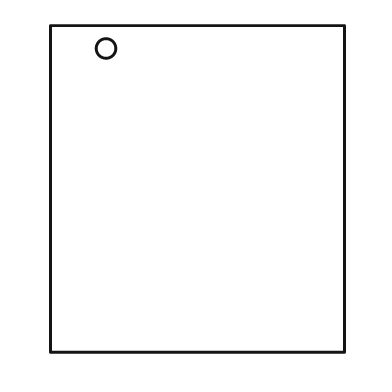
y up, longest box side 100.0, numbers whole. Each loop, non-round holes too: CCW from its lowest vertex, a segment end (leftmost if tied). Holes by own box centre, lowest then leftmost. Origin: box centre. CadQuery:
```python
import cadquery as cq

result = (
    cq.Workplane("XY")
    .moveTo(-45.0, -50.0)
    .lineTo(45.0, -50.0)
    .lineTo(45.0, 50.0)
    .lineTo(-45.0, 50.0)
    .close()
    .moveTo(-28.0, 43.0)
    .circle(3.0)
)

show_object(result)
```